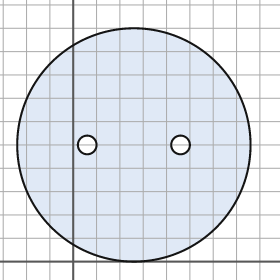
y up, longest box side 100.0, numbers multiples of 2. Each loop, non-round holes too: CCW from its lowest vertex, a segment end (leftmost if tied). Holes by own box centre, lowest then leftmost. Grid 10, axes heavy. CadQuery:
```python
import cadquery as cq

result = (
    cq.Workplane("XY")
    .moveTo(26.0, 50.0)
    .circle(50.0)
    .moveTo(6.0, 50.0)
    .circle(4.0)
    .moveTo(46.0, 50.0)
    .circle(4.0)
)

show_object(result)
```